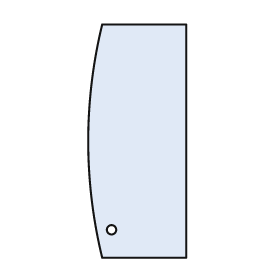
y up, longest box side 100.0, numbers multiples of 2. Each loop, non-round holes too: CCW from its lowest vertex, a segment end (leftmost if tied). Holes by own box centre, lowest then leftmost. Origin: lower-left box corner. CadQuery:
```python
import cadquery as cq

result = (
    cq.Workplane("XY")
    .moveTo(6.0, 0.0)
    .lineTo(42.0, 0.0)
    .lineTo(42.0, 100.0)
    .lineTo(6.0, 100.0)
    .threePointArc((0.0, 50.0), (6.0, 0.0))
    .close()
    .moveTo(10.0, 12.0)
    .circle(2.0)
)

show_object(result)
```